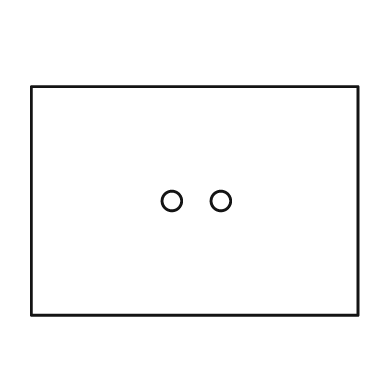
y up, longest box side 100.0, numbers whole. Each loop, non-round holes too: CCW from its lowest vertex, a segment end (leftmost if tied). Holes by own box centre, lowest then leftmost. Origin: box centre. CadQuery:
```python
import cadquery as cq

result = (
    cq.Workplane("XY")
    .moveTo(-50.0, -35.0)
    .lineTo(50.0, -35.0)
    .lineTo(50.0, 35.0)
    .lineTo(-50.0, 35.0)
    .close()
    .moveTo(-7.0, 0.0)
    .circle(3.0)
    .moveTo(8.0, 0.0)
    .circle(3.0)
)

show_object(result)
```